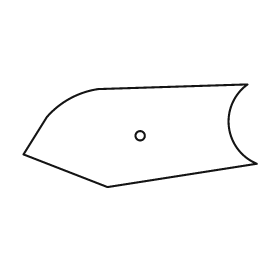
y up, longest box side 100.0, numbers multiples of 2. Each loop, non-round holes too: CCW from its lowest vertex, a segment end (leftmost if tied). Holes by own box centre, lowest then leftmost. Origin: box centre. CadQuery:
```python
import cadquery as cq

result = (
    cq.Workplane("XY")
    .moveTo(-14.0, -22.0)
    .lineTo(50.0, -12.0)
    .threePointArc((38.0, 4.0), (46.0, 22.0))
    .lineTo(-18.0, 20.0)
    .threePointArc((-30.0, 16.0), (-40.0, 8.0))
    .lineTo(-50.0, -8.0)
    .close()
    .moveTo(0.0, 0.0)
    .circle(2.0)
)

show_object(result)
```